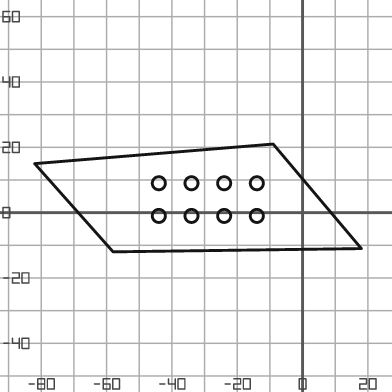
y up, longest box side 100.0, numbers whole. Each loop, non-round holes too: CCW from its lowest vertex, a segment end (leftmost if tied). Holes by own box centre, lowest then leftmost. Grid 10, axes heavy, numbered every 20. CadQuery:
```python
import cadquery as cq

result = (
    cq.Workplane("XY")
    .moveTo(-58.0, -12.0)
    .lineTo(18.0, -11.0)
    .lineTo(-9.0, 21.0)
    .lineTo(-82.0, 15.0)
    .close()
    .moveTo(-44.0, -1.0)
    .circle(2.0)
    .moveTo(-34.0, -1.0)
    .circle(2.0)
    .moveTo(-24.0, -1.0)
    .circle(2.0)
    .moveTo(-14.0, -1.0)
    .circle(2.0)
    .moveTo(-44.0, 9.0)
    .circle(2.0)
    .moveTo(-34.0, 9.0)
    .circle(2.0)
    .moveTo(-24.0, 9.0)
    .circle(2.0)
    .moveTo(-14.0, 9.0)
    .circle(2.0)
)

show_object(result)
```